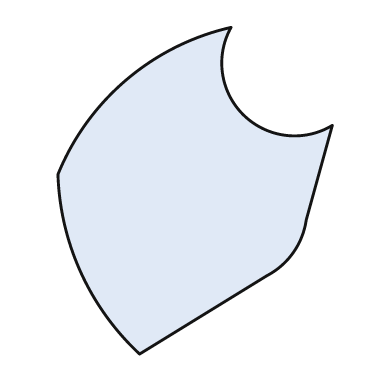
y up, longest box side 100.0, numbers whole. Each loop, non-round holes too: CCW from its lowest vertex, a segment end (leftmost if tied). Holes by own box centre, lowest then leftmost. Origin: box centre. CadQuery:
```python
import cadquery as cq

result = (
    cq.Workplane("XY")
    .moveTo(-17.0, -50.0)
    .lineTo(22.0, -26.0)
    .threePointArc((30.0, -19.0), (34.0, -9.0))
    .lineTo(42.0, 20.0)
    .threePointArc((15.0, 23.0), (11.0, 50.0))
    .threePointArc((-21.0, 34.0), (-42.0, 5.0))
    .threePointArc((-35.0, -25.0), (-17.0, -50.0))
    .close()
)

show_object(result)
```